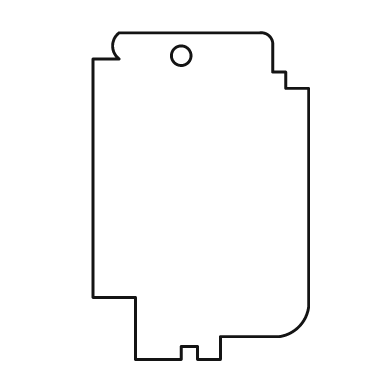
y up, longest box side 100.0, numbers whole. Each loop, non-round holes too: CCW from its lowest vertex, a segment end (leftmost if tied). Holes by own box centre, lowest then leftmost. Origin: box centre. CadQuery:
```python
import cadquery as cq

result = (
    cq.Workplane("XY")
    .moveTo(-20.0, -50.0)
    .lineTo(-6.0, -50.0)
    .lineTo(-6.0, -46.0)
    .lineTo(-1.0, -46.0)
    .lineTo(-1.0, -50.0)
    .lineTo(6.0, -50.0)
    .lineTo(6.0, -43.0)
    .lineTo(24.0, -43.0)
    .threePointArc((30.0, -40.0), (33.0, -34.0))
    .lineTo(33.0, 33.0)
    .lineTo(26.0, 33.0)
    .lineTo(26.0, 38.0)
    .lineTo(22.0, 38.0)
    .lineTo(22.0, 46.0)
    .threePointArc((21.0, 49.0), (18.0, 50.0))
    .lineTo(-25.0, 50.0)
    .threePointArc((-27.0, 46.0), (-25.0, 42.0))
    .lineTo(-33.0, 42.0)
    .lineTo(-33.0, -31.0)
    .lineTo(-20.0, -31.0)
    .close()
    .moveTo(-6.0, 43.0)
    .circle(3.0)
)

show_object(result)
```